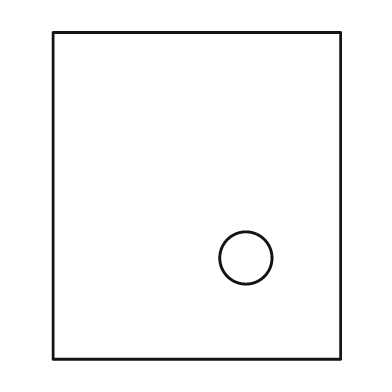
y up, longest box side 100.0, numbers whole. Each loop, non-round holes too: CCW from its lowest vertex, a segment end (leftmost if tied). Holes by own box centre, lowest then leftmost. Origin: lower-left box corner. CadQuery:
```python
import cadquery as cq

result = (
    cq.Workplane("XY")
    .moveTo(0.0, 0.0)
    .lineTo(88.0, 0.0)
    .lineTo(88.0, 100.0)
    .lineTo(0.0, 100.0)
    .close()
    .moveTo(59.0, 31.0)
    .circle(8.0)
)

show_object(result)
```